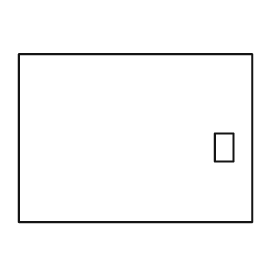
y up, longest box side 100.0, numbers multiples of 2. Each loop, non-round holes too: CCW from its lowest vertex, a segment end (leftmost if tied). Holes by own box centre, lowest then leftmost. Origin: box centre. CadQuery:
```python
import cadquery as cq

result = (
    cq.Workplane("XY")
    .moveTo(-50.0, -36.0)
    .lineTo(50.0, -36.0)
    .lineTo(50.0, 36.0)
    .lineTo(-50.0, 36.0)
    .close()
    .moveTo(34.0, -10.0)
    .lineTo(42.0, -10.0)
    .lineTo(42.0, 2.0)
    .lineTo(34.0, 2.0)
    .close()
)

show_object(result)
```